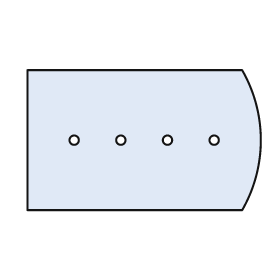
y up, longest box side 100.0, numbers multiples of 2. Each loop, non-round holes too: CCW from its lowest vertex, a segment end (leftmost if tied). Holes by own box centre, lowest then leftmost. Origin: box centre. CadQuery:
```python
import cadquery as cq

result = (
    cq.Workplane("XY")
    .moveTo(-50.0, -30.0)
    .lineTo(42.0, -30.0)
    .threePointArc((50.0, 0.0), (42.0, 30.0))
    .lineTo(-50.0, 30.0)
    .close()
    .moveTo(-30.0, 0.0)
    .circle(2.0)
    .moveTo(-10.0, 0.0)
    .circle(2.0)
    .moveTo(10.0, 0.0)
    .circle(2.0)
    .moveTo(30.0, 0.0)
    .circle(2.0)
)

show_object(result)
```